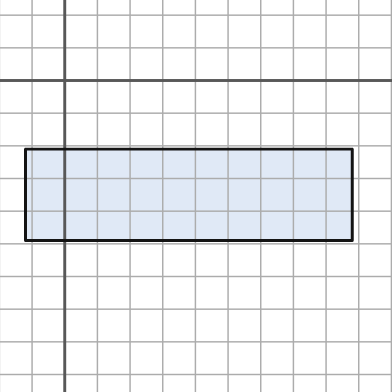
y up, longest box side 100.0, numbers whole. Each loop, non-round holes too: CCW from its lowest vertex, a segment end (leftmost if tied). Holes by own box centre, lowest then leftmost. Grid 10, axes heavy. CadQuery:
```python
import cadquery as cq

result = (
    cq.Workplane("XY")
    .moveTo(-12.0, -49.0)
    .lineTo(88.0, -49.0)
    .lineTo(88.0, -21.0)
    .lineTo(-12.0, -21.0)
    .close()
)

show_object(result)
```